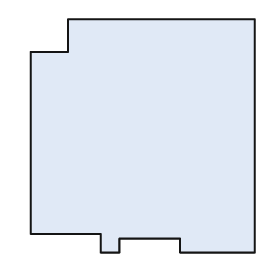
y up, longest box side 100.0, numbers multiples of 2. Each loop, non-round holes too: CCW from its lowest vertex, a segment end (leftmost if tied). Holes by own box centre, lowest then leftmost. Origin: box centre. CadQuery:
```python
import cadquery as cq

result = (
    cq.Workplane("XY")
    .moveTo(-18.0, -50.0)
    .lineTo(-10.0, -50.0)
    .lineTo(-10.0, -44.0)
    .lineTo(16.0, -44.0)
    .lineTo(16.0, -50.0)
    .lineTo(48.0, -50.0)
    .lineTo(48.0, 50.0)
    .lineTo(-32.0, 50.0)
    .lineTo(-32.0, 36.0)
    .lineTo(-48.0, 36.0)
    .lineTo(-48.0, -42.0)
    .lineTo(-18.0, -42.0)
    .close()
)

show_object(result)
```